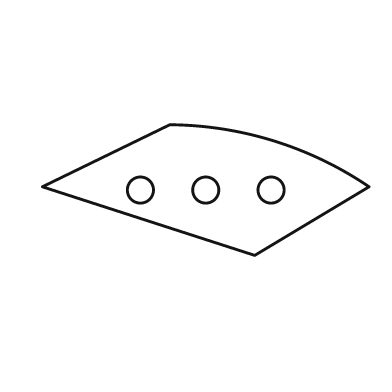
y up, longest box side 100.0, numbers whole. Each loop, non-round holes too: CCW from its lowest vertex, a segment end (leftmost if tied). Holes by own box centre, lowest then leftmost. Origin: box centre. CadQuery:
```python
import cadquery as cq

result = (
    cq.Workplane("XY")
    .moveTo(15.0, -20.0)
    .lineTo(50.0, 1.0)
    .threePointArc((21.0, 15.0), (-11.0, 20.0))
    .lineTo(-50.0, 1.0)
    .close()
    .moveTo(-20.0, 0.0)
    .circle(4.0)
    .moveTo(0.0, 0.0)
    .circle(4.0)
    .moveTo(20.0, 0.0)
    .circle(4.0)
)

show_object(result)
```